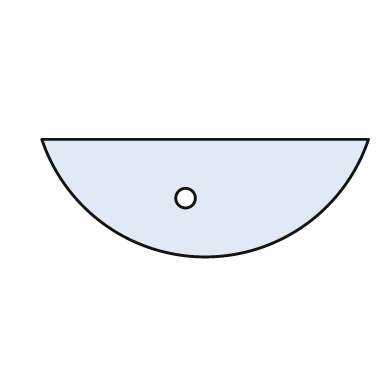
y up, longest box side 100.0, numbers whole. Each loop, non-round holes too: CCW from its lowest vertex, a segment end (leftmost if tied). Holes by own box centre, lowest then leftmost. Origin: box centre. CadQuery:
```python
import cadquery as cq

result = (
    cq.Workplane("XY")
    .moveTo(-50.0, 18.0)
    .threePointArc((0.0, -18.0), (50.0, 18.0))
    .close()
    .moveTo(-6.0, 0.0)
    .circle(3.0)
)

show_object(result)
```